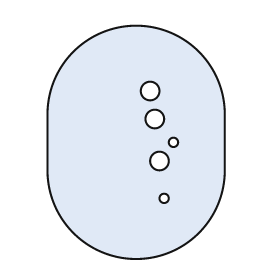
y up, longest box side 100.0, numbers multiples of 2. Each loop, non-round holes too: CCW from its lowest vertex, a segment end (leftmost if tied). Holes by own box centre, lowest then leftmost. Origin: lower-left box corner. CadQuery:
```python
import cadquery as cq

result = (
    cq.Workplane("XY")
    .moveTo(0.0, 38.0)
    .threePointArc((38.0, 0.0), (76.0, 38.0))
    .lineTo(76.0, 62.0)
    .threePointArc((38.0, 100.0), (0.0, 62.0))
    .close()
    .moveTo(50.0, 26.0)
    .circle(2.0)
    .moveTo(48.0, 42.0)
    .circle(4.0)
    .moveTo(54.0, 50.0)
    .circle(2.0)
    .moveTo(46.0, 60.0)
    .circle(4.0)
    .moveTo(44.0, 72.0)
    .circle(4.0)
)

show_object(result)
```